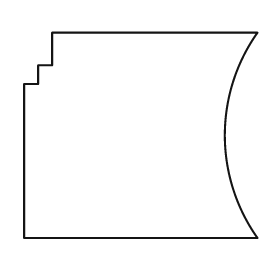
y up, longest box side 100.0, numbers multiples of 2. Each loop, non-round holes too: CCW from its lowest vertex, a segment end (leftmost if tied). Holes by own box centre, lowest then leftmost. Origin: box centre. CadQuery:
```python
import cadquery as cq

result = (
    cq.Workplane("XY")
    .moveTo(-50.0, -44.0)
    .lineTo(50.0, -44.0)
    .threePointArc((36.0, 0.0), (50.0, 44.0))
    .lineTo(-38.0, 44.0)
    .lineTo(-38.0, 30.0)
    .lineTo(-44.0, 30.0)
    .lineTo(-44.0, 22.0)
    .lineTo(-50.0, 22.0)
    .close()
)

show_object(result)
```